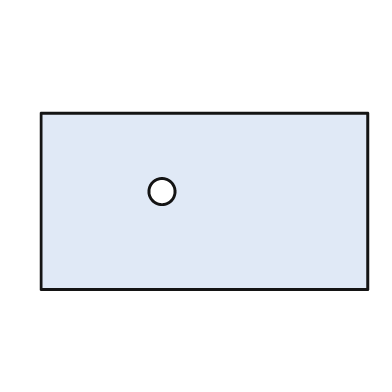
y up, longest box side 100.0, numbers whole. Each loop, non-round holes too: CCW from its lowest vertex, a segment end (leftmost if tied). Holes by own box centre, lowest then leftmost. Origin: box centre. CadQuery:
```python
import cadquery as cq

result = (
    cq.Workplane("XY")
    .moveTo(-50.0, -27.0)
    .lineTo(50.0, -27.0)
    .lineTo(50.0, 27.0)
    .lineTo(-50.0, 27.0)
    .close()
    .moveTo(-13.0, 3.0)
    .circle(4.0)
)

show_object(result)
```